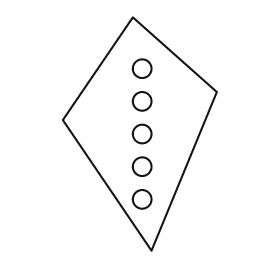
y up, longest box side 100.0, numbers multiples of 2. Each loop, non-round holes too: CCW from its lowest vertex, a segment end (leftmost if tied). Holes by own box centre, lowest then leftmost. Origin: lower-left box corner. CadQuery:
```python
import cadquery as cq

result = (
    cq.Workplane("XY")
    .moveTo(38.0, 0.0)
    .lineTo(66.0, 68.0)
    .lineTo(30.0, 100.0)
    .lineTo(0.0, 56.0)
    .close()
    .moveTo(34.0, 22.0)
    .circle(4.0)
    .moveTo(34.0, 36.0)
    .circle(4.0)
    .moveTo(34.0, 50.0)
    .circle(4.0)
    .moveTo(34.0, 64.0)
    .circle(4.0)
    .moveTo(34.0, 78.0)
    .circle(4.0)
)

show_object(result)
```